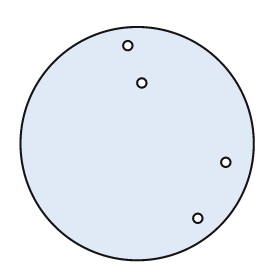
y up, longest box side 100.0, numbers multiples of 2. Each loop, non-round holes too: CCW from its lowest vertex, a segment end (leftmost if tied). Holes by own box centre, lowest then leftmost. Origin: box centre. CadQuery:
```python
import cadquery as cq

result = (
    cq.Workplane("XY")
    .moveTo(0.0, 0.0)
    .circle(50.0)
    .moveTo(26.0, -32.0)
    .circle(2.0)
    .moveTo(38.0, -8.0)
    .circle(2.0)
    .moveTo(2.0, 26.0)
    .circle(2.0)
    .moveTo(-4.0, 42.0)
    .circle(2.0)
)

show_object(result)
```